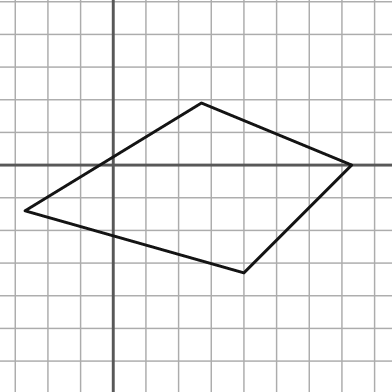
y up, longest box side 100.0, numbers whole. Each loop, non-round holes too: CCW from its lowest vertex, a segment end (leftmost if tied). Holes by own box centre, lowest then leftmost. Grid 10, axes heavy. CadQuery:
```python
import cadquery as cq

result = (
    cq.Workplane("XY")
    .moveTo(40.0, -33.0)
    .lineTo(73.0, 0.0)
    .lineTo(27.0, 19.0)
    .lineTo(-27.0, -14.0)
    .close()
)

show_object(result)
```